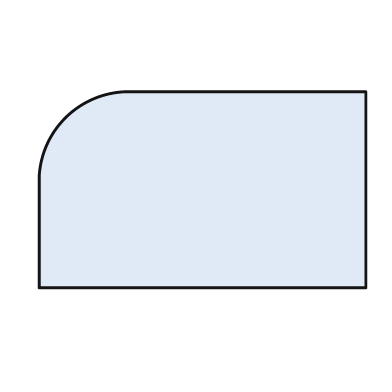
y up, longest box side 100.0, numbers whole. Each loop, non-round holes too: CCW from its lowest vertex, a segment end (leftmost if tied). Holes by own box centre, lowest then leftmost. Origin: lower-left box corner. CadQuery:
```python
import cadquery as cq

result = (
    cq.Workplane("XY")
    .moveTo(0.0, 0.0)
    .lineTo(100.0, 0.0)
    .lineTo(100.0, 60.0)
    .lineTo(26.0, 60.0)
    .threePointArc((8.0, 52.0), (0.0, 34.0))
    .close()
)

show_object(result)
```